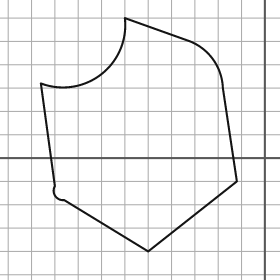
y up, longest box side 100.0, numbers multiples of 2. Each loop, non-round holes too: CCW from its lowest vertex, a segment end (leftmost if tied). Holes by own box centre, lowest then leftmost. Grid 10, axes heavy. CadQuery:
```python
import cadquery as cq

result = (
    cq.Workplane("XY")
    .moveTo(-50.0, -40.0)
    .lineTo(-12.0, -10.0)
    .lineTo(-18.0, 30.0)
    .threePointArc((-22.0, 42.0), (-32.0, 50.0))
    .lineTo(-60.0, 60.0)
    .threePointArc((-70.0, 36.0), (-96.0, 32.0))
    .lineTo(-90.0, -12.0)
    .threePointArc((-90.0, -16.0), (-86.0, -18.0))
    .close()
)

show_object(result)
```